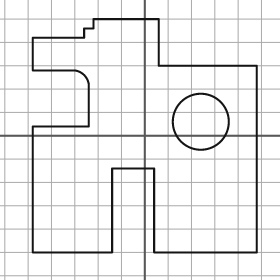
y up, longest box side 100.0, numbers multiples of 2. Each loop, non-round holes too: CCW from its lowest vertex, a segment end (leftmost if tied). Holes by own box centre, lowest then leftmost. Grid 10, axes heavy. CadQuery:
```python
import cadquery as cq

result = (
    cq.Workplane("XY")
    .moveTo(-48.0, -50.0)
    .lineTo(-14.0, -50.0)
    .lineTo(-14.0, -14.0)
    .lineTo(4.0, -14.0)
    .lineTo(4.0, -50.0)
    .lineTo(48.0, -50.0)
    .lineTo(48.0, 30.0)
    .lineTo(6.0, 30.0)
    .lineTo(6.0, 50.0)
    .lineTo(-22.0, 50.0)
    .lineTo(-22.0, 46.0)
    .lineTo(-26.0, 46.0)
    .lineTo(-26.0, 42.0)
    .lineTo(-48.0, 42.0)
    .lineTo(-48.0, 28.0)
    .lineTo(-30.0, 28.0)
    .threePointArc((-26.0, 26.0), (-24.0, 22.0))
    .lineTo(-24.0, 4.0)
    .lineTo(-48.0, 4.0)
    .close()
    .moveTo(24.0, 6.0)
    .circle(12.0)
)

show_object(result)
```